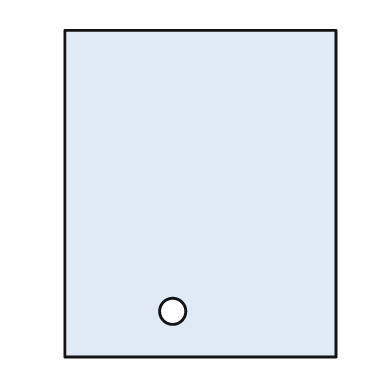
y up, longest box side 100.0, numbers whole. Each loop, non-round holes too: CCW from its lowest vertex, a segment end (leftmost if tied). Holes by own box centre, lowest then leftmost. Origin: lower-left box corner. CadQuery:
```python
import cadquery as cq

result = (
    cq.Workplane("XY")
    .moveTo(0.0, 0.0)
    .lineTo(83.0, 0.0)
    .lineTo(83.0, 100.0)
    .lineTo(0.0, 100.0)
    .close()
    .moveTo(33.0, 14.0)
    .circle(4.0)
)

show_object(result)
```